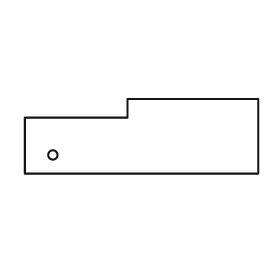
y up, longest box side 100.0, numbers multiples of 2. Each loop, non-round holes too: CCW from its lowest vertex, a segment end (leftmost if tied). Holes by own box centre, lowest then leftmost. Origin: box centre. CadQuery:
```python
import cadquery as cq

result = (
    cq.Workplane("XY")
    .moveTo(-50.0, -16.0)
    .lineTo(50.0, -16.0)
    .lineTo(50.0, 16.0)
    .lineTo(-6.0, 16.0)
    .lineTo(-6.0, 8.0)
    .lineTo(-50.0, 8.0)
    .close()
    .moveTo(-38.0, -8.0)
    .circle(2.0)
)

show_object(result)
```